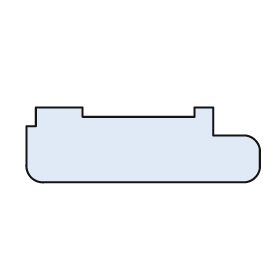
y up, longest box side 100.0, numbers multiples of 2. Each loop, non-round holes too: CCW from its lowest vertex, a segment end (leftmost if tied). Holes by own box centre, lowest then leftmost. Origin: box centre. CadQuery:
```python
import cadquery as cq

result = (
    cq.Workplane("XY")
    .moveTo(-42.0, -16.0)
    .lineTo(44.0, -16.0)
    .threePointArc((48.0, -14.0), (50.0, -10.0))
    .lineTo(50.0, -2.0)
    .threePointArc((48.0, 2.0), (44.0, 4.0))
    .lineTo(30.0, 4.0)
    .lineTo(30.0, 16.0)
    .lineTo(22.0, 16.0)
    .lineTo(22.0, 12.0)
    .lineTo(-26.0, 12.0)
    .lineTo(-26.0, 16.0)
    .lineTo(-46.0, 16.0)
    .lineTo(-46.0, 8.0)
    .lineTo(-50.0, 8.0)
    .lineTo(-50.0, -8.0)
    .threePointArc((-48.0, -14.0), (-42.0, -16.0))
    .close()
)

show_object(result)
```